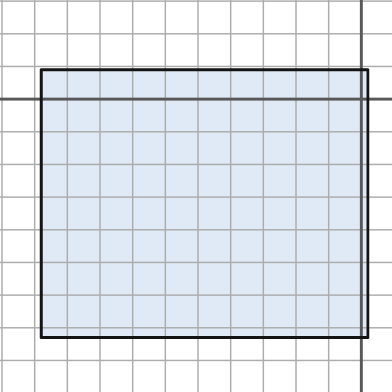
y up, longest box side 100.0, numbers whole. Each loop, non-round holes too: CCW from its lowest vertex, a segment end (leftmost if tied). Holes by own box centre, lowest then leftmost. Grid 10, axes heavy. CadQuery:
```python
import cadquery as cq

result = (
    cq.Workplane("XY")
    .moveTo(-98.0, -73.0)
    .lineTo(2.0, -73.0)
    .lineTo(2.0, 9.0)
    .lineTo(-98.0, 9.0)
    .close()
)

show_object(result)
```